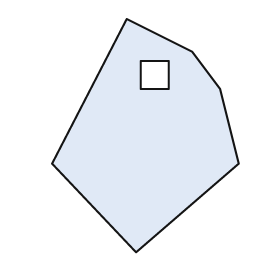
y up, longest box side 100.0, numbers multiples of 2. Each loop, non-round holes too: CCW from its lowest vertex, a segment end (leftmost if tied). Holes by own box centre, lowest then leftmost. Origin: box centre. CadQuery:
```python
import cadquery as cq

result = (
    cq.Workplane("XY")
    .moveTo(-4.0, -50.0)
    .lineTo(40.0, -12.0)
    .lineTo(32.0, 20.0)
    .lineTo(20.0, 36.0)
    .lineTo(-8.0, 50.0)
    .lineTo(-40.0, -12.0)
    .close()
    .moveTo(-2.0, 20.0)
    .lineTo(10.0, 20.0)
    .lineTo(10.0, 32.0)
    .lineTo(-2.0, 32.0)
    .close()
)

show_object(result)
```